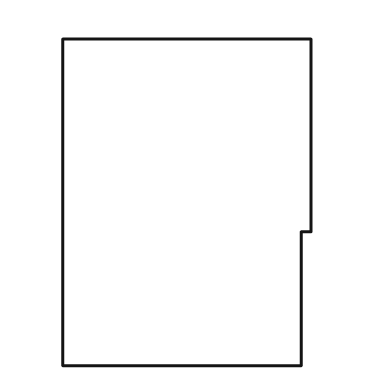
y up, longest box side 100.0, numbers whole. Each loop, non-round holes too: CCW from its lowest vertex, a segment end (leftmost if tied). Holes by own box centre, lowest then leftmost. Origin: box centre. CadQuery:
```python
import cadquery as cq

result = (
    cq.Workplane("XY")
    .moveTo(-38.0, -50.0)
    .lineTo(35.0, -50.0)
    .lineTo(35.0, -9.0)
    .lineTo(38.0, -9.0)
    .lineTo(38.0, 50.0)
    .lineTo(-38.0, 50.0)
    .close()
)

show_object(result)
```